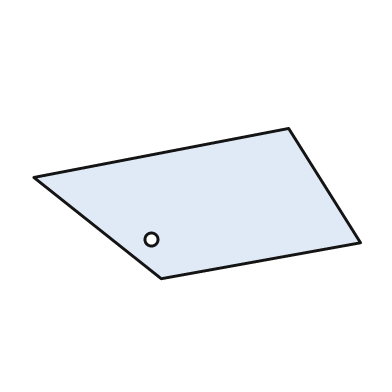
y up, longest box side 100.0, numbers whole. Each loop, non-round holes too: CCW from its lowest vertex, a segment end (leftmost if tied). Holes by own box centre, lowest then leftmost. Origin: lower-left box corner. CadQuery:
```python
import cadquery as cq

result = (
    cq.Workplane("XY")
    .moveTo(39.0, 0.0)
    .lineTo(100.0, 11.0)
    .lineTo(78.0, 46.0)
    .lineTo(0.0, 31.0)
    .close()
    .moveTo(36.0, 12.0)
    .circle(2.0)
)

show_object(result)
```